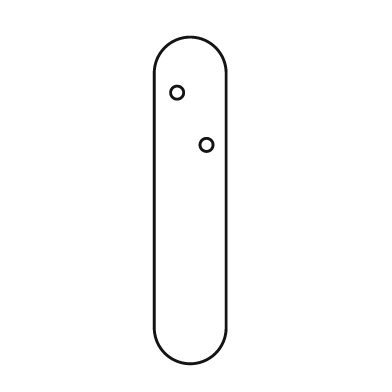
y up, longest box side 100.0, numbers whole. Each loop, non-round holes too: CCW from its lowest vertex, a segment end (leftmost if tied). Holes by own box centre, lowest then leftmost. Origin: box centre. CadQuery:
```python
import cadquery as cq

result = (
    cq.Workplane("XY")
    .moveTo(-11.0, -39.0)
    .threePointArc((0.0, -50.0), (11.0, -39.0))
    .lineTo(11.0, 39.0)
    .threePointArc((0.0, 50.0), (-11.0, 39.0))
    .close()
    .moveTo(5.0, 17.0)
    .circle(2.0)
    .moveTo(-4.0, 33.0)
    .circle(2.0)
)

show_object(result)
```